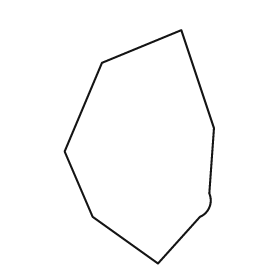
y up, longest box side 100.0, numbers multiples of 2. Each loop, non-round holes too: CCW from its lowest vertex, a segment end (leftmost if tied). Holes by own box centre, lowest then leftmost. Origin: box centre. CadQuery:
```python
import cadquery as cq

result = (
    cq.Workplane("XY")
    .moveTo(8.0, -50.0)
    .lineTo(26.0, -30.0)
    .threePointArc((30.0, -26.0), (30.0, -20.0))
    .lineTo(32.0, 8.0)
    .lineTo(18.0, 50.0)
    .lineTo(-16.0, 36.0)
    .lineTo(-32.0, -2.0)
    .lineTo(-20.0, -30.0)
    .close()
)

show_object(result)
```